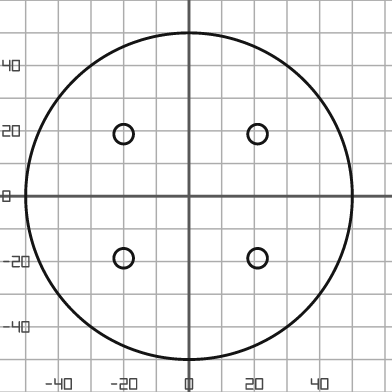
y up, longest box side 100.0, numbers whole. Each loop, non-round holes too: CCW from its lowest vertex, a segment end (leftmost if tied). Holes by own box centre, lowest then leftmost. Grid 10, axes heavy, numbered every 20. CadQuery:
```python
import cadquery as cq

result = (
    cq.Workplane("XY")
    .moveTo(0.0, 0.0)
    .circle(50.0)
    .moveTo(-20.0, -19.0)
    .circle(3.0)
    .moveTo(21.0, -19.0)
    .circle(3.0)
    .moveTo(-20.0, 19.0)
    .circle(3.0)
    .moveTo(21.0, 19.0)
    .circle(3.0)
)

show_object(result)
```